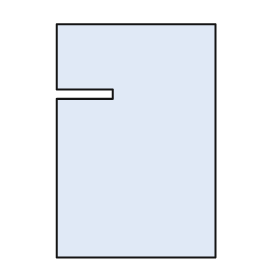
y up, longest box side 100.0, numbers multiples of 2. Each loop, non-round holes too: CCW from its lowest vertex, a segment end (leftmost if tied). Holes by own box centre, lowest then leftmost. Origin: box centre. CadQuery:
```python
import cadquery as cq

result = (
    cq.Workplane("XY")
    .moveTo(-34.0, -50.0)
    .lineTo(34.0, -50.0)
    .lineTo(34.0, 50.0)
    .lineTo(-34.0, 50.0)
    .lineTo(-34.0, 22.0)
    .lineTo(-10.0, 22.0)
    .lineTo(-10.0, 18.0)
    .lineTo(-34.0, 18.0)
    .close()
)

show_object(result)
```